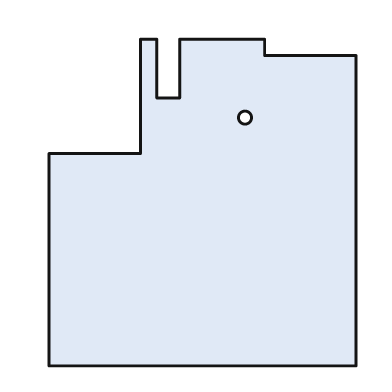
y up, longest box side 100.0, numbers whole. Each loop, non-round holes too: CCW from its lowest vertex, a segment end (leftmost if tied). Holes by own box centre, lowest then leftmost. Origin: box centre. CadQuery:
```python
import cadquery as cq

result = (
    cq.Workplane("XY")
    .moveTo(-47.0, -50.0)
    .lineTo(47.0, -50.0)
    .lineTo(47.0, 45.0)
    .lineTo(19.0, 45.0)
    .lineTo(19.0, 50.0)
    .lineTo(-7.0, 50.0)
    .lineTo(-7.0, 32.0)
    .lineTo(-14.0, 32.0)
    .lineTo(-14.0, 50.0)
    .lineTo(-19.0, 50.0)
    .lineTo(-19.0, 15.0)
    .lineTo(-47.0, 15.0)
    .close()
    .moveTo(13.0, 26.0)
    .circle(2.0)
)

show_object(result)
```